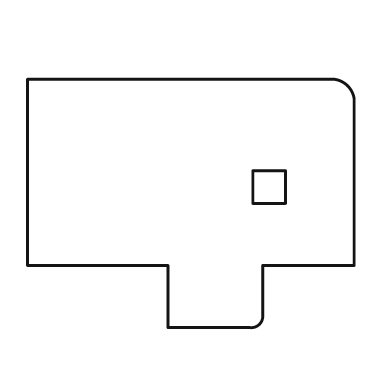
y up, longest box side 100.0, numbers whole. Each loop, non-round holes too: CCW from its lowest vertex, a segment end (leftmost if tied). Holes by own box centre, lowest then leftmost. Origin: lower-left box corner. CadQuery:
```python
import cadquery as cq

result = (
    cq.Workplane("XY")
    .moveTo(43.0, 0.0)
    .lineTo(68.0, 0.0)
    .threePointArc((71.0, 1.0), (72.0, 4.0))
    .lineTo(72.0, 19.0)
    .lineTo(100.0, 19.0)
    .lineTo(100.0, 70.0)
    .threePointArc((98.0, 74.0), (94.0, 76.0))
    .lineTo(0.0, 76.0)
    .lineTo(0.0, 19.0)
    .lineTo(43.0, 19.0)
    .close()
    .moveTo(69.0, 38.0)
    .lineTo(79.0, 38.0)
    .lineTo(79.0, 48.0)
    .lineTo(69.0, 48.0)
    .close()
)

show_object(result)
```